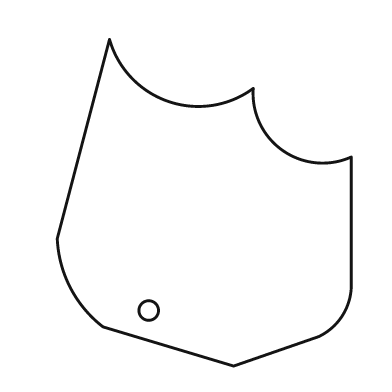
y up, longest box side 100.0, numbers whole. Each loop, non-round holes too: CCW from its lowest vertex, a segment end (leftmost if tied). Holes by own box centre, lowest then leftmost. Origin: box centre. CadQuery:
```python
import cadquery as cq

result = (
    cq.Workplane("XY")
    .moveTo(9.0, -50.0)
    .lineTo(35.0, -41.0)
    .threePointArc((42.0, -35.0), (45.0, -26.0))
    .lineTo(45.0, 14.0)
    .threePointArc((24.0, 16.0), (15.0, 35.0))
    .threePointArc((-11.0, 31.0), (-29.0, 50.0))
    .lineTo(-45.0, -11.0)
    .threePointArc((-41.0, -26.0), (-31.0, -38.0))
    .close()
    .moveTo(-17.0, -33.0)
    .circle(3.0)
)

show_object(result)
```